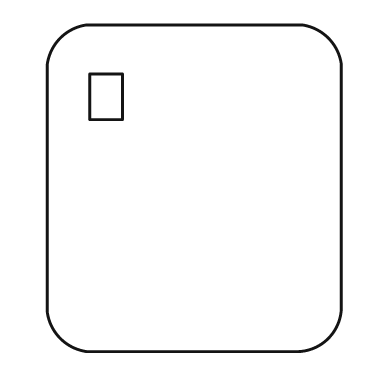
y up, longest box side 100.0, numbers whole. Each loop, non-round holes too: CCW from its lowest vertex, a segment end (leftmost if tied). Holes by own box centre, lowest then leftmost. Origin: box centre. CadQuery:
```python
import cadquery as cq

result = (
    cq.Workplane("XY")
    .moveTo(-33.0, -50.0)
    .lineTo(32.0, -50.0)
    .threePointArc((41.0, -46.0), (45.0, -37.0))
    .lineTo(45.0, 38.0)
    .threePointArc((41.0, 46.0), (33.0, 50.0))
    .lineTo(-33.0, 50.0)
    .threePointArc((-41.0, 46.0), (-45.0, 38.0))
    .lineTo(-45.0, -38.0)
    .threePointArc((-41.0, -46.0), (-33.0, -50.0))
    .close()
    .moveTo(-32.0, 21.0)
    .lineTo(-22.0, 21.0)
    .lineTo(-22.0, 35.0)
    .lineTo(-32.0, 35.0)
    .close()
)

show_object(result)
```